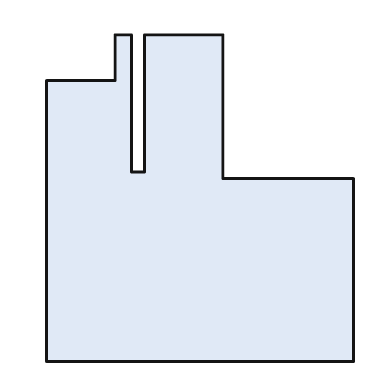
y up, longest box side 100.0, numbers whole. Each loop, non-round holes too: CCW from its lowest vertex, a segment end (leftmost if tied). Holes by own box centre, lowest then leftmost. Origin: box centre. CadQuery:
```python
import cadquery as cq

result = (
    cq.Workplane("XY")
    .moveTo(-47.0, -50.0)
    .lineTo(47.0, -50.0)
    .lineTo(47.0, 6.0)
    .lineTo(7.0, 6.0)
    .lineTo(7.0, 50.0)
    .lineTo(-17.0, 50.0)
    .lineTo(-17.0, 8.0)
    .lineTo(-21.0, 8.0)
    .lineTo(-21.0, 50.0)
    .lineTo(-26.0, 50.0)
    .lineTo(-26.0, 36.0)
    .lineTo(-47.0, 36.0)
    .close()
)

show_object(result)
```